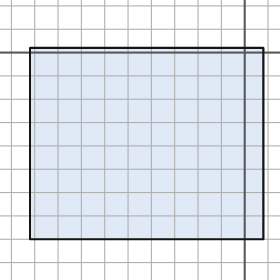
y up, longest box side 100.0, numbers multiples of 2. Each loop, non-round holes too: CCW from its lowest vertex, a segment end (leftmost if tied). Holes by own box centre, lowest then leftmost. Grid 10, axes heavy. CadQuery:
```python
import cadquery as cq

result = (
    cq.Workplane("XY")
    .moveTo(-92.0, -80.0)
    .lineTo(8.0, -80.0)
    .lineTo(8.0, 2.0)
    .lineTo(-92.0, 2.0)
    .close()
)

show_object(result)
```